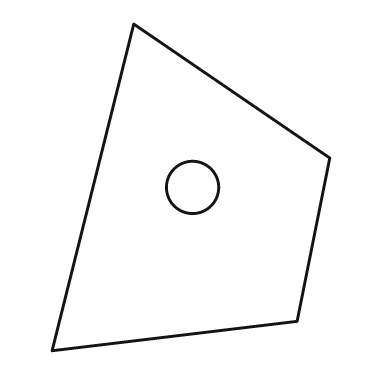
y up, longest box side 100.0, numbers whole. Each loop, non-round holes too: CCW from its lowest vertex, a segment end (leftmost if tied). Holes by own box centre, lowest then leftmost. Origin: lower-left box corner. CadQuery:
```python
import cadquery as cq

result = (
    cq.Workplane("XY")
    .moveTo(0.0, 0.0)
    .lineTo(75.0, 9.0)
    .lineTo(85.0, 59.0)
    .lineTo(25.0, 100.0)
    .close()
    .moveTo(43.0, 50.0)
    .circle(8.0)
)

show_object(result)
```